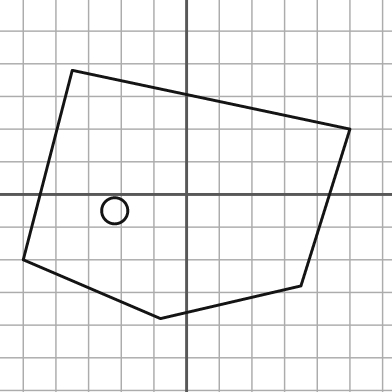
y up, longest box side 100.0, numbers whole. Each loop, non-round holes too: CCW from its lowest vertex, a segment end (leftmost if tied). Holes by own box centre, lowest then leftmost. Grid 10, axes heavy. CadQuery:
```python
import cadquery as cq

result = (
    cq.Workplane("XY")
    .moveTo(-8.0, -38.0)
    .lineTo(35.0, -28.0)
    .lineTo(50.0, 20.0)
    .lineTo(-35.0, 38.0)
    .lineTo(-50.0, -20.0)
    .close()
    .moveTo(-22.0, -5.0)
    .circle(4.0)
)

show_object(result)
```